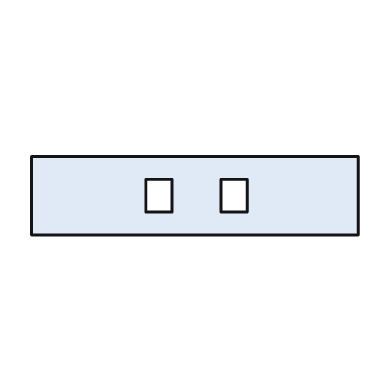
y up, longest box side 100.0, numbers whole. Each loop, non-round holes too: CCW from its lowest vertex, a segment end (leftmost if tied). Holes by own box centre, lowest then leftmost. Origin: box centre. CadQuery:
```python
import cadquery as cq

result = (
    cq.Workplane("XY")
    .moveTo(-50.0, -12.0)
    .lineTo(50.0, -12.0)
    .lineTo(50.0, 12.0)
    .lineTo(-50.0, 12.0)
    .close()
    .moveTo(-15.0, -5.0)
    .lineTo(-7.0, -5.0)
    .lineTo(-7.0, 5.0)
    .lineTo(-15.0, 5.0)
    .close()
    .moveTo(8.0, -5.0)
    .lineTo(16.0, -5.0)
    .lineTo(16.0, 5.0)
    .lineTo(8.0, 5.0)
    .close()
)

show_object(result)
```